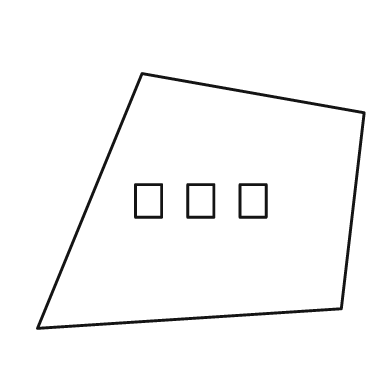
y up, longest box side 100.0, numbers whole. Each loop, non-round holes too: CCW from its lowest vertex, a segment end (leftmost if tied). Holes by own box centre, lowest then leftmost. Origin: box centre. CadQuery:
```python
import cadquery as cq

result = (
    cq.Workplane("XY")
    .moveTo(-50.0, -39.0)
    .lineTo(43.0, -33.0)
    .lineTo(50.0, 27.0)
    .lineTo(-18.0, 39.0)
    .close()
    .moveTo(-20.0, -5.0)
    .lineTo(-12.0, -5.0)
    .lineTo(-12.0, 5.0)
    .lineTo(-20.0, 5.0)
    .close()
    .moveTo(-4.0, -5.0)
    .lineTo(4.0, -5.0)
    .lineTo(4.0, 5.0)
    .lineTo(-4.0, 5.0)
    .close()
    .moveTo(12.0, -5.0)
    .lineTo(20.0, -5.0)
    .lineTo(20.0, 5.0)
    .lineTo(12.0, 5.0)
    .close()
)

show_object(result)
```